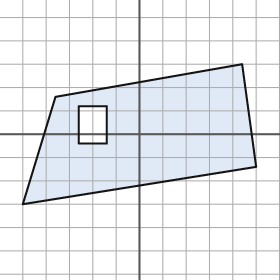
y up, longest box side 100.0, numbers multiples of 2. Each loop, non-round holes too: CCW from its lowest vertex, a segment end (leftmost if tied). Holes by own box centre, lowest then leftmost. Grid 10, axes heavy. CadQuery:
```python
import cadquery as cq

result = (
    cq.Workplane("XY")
    .moveTo(-50.0, -30.0)
    .lineTo(50.0, -14.0)
    .lineTo(44.0, 30.0)
    .lineTo(-36.0, 16.0)
    .close()
    .moveTo(-26.0, -4.0)
    .lineTo(-14.0, -4.0)
    .lineTo(-14.0, 12.0)
    .lineTo(-26.0, 12.0)
    .close()
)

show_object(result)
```